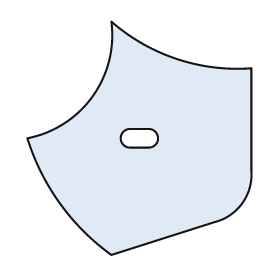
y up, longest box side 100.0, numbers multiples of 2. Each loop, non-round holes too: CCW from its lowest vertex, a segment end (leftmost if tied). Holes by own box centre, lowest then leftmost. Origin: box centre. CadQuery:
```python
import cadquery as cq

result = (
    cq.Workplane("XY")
    .moveTo(-12.0, -50.0)
    .lineTo(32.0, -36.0)
    .threePointArc((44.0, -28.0), (48.0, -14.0))
    .lineTo(48.0, 30.0)
    .threePointArc((16.0, 34.0), (-12.0, 50.0))
    .threePointArc((-20.0, 18.0), (-48.0, 0.0))
    .threePointArc((-34.0, -28.0), (-12.0, -50.0))
    .close()
    .moveTo(-4.0, -4.0)
    .lineTo(4.0, -4.0)
    .threePointArc((8.0, 0.0), (4.0, 4.0))
    .lineTo(-4.0, 4.0)
    .threePointArc((-8.0, 0.0), (-4.0, -4.0))
    .close()
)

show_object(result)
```